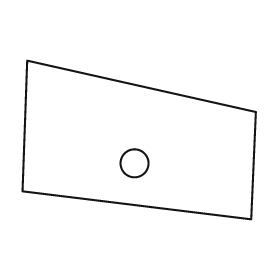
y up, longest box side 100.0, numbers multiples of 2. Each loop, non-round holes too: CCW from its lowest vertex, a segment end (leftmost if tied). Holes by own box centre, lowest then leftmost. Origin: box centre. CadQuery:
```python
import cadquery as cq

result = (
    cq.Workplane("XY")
    .moveTo(48.0, -34.0)
    .lineTo(50.0, 12.0)
    .lineTo(-48.0, 34.0)
    .lineTo(-50.0, -22.0)
    .close()
    .moveTo(-2.0, -10.0)
    .circle(6.0)
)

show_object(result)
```